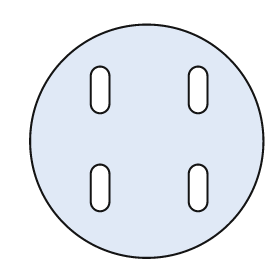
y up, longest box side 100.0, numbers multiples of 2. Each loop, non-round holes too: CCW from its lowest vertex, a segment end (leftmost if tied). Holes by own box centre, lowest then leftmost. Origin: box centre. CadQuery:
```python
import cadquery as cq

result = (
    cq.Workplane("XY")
    .moveTo(0.0, 0.0)
    .circle(50.0)
    .moveTo(-24.0, -26.0)
    .threePointArc((-20.0, -30.0), (-16.0, -26.0))
    .lineTo(-16.0, -14.0)
    .threePointArc((-20.0, -10.0), (-24.0, -14.0))
    .close()
    .moveTo(18.0, -26.0)
    .threePointArc((22.0, -30.0), (26.0, -26.0))
    .lineTo(26.0, -14.0)
    .threePointArc((22.0, -10.0), (18.0, -14.0))
    .close()
    .moveTo(-24.0, 16.0)
    .threePointArc((-20.0, 12.0), (-16.0, 16.0))
    .lineTo(-16.0, 28.0)
    .threePointArc((-20.0, 32.0), (-24.0, 28.0))
    .close()
    .moveTo(18.0, 16.0)
    .threePointArc((22.0, 12.0), (26.0, 16.0))
    .lineTo(26.0, 28.0)
    .threePointArc((22.0, 32.0), (18.0, 28.0))
    .close()
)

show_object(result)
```